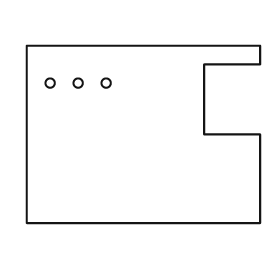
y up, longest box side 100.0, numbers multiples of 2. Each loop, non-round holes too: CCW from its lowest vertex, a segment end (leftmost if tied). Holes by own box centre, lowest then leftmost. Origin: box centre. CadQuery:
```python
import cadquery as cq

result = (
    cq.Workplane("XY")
    .moveTo(-50.0, -38.0)
    .lineTo(50.0, -38.0)
    .lineTo(50.0, 0.0)
    .lineTo(26.0, 0.0)
    .lineTo(26.0, 30.0)
    .lineTo(50.0, 30.0)
    .lineTo(50.0, 38.0)
    .lineTo(-50.0, 38.0)
    .close()
    .moveTo(-40.0, 22.0)
    .circle(2.0)
    .moveTo(-28.0, 22.0)
    .circle(2.0)
    .moveTo(-16.0, 22.0)
    .circle(2.0)
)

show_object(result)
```